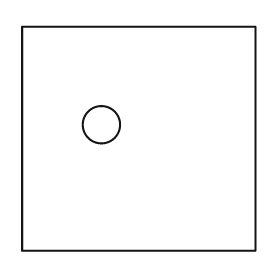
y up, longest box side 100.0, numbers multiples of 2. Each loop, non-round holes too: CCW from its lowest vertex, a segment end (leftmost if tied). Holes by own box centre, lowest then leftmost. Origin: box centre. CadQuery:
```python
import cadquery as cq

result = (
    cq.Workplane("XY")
    .moveTo(-50.0, -48.0)
    .lineTo(50.0, -48.0)
    .lineTo(50.0, 48.0)
    .lineTo(-50.0, 48.0)
    .close()
    .moveTo(-16.0, 6.0)
    .circle(8.0)
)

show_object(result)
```